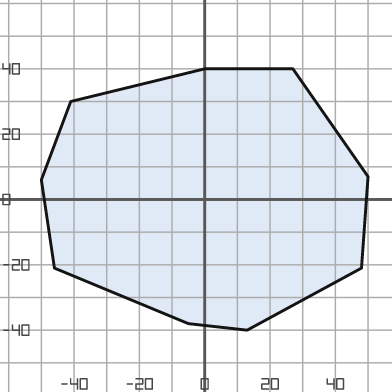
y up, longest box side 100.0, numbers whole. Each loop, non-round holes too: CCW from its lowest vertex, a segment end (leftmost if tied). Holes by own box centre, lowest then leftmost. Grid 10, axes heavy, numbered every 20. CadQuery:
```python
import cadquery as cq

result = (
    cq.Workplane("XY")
    .moveTo(13.0, -40.0)
    .lineTo(48.0, -21.0)
    .lineTo(50.0, 7.0)
    .lineTo(27.0, 40.0)
    .lineTo(0.0, 40.0)
    .lineTo(-41.0, 30.0)
    .lineTo(-50.0, 6.0)
    .lineTo(-46.0, -21.0)
    .lineTo(-5.0, -38.0)
    .close()
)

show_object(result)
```